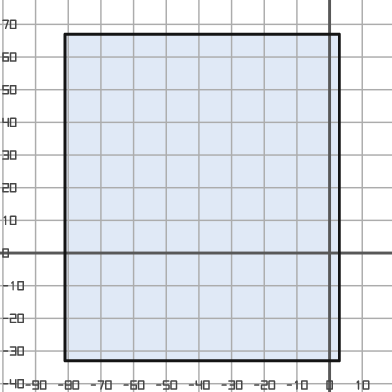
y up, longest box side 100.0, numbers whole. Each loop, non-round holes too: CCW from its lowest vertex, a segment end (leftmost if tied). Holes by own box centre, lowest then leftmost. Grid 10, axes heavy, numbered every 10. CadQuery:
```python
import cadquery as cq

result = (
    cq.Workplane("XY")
    .moveTo(-81.0, -33.0)
    .lineTo(3.0, -33.0)
    .lineTo(3.0, 67.0)
    .lineTo(-81.0, 67.0)
    .close()
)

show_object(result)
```